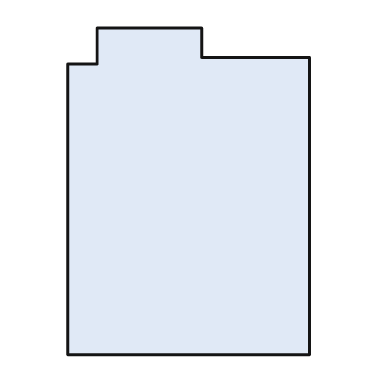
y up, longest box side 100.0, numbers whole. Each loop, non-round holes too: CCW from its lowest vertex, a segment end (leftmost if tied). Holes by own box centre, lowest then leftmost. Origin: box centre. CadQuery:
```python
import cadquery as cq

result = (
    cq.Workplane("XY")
    .moveTo(-37.0, -50.0)
    .lineTo(37.0, -50.0)
    .lineTo(37.0, 41.0)
    .lineTo(4.0, 41.0)
    .lineTo(4.0, 50.0)
    .lineTo(-28.0, 50.0)
    .lineTo(-28.0, 39.0)
    .lineTo(-37.0, 39.0)
    .close()
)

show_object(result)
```